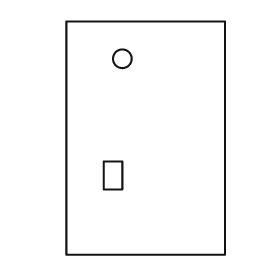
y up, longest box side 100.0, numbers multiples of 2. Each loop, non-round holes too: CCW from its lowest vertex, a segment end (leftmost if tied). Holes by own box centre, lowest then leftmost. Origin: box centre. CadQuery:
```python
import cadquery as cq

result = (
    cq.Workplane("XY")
    .moveTo(-34.0, -50.0)
    .lineTo(34.0, -50.0)
    .lineTo(34.0, 50.0)
    .lineTo(-34.0, 50.0)
    .close()
    .moveTo(-18.0, -22.0)
    .lineTo(-10.0, -22.0)
    .lineTo(-10.0, -10.0)
    .lineTo(-18.0, -10.0)
    .close()
    .moveTo(-10.0, 34.0)
    .circle(4.0)
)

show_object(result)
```